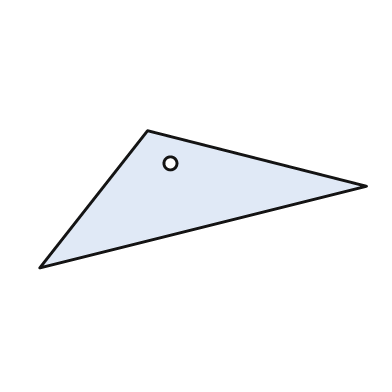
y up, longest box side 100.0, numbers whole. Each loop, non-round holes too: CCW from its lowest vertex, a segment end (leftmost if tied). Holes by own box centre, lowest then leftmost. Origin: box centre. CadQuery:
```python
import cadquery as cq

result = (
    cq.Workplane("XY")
    .moveTo(-50.0, -21.0)
    .lineTo(50.0, 4.0)
    .lineTo(-17.0, 21.0)
    .close()
    .moveTo(-10.0, 11.0)
    .circle(2.0)
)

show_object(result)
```